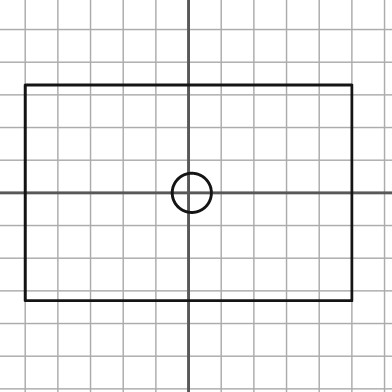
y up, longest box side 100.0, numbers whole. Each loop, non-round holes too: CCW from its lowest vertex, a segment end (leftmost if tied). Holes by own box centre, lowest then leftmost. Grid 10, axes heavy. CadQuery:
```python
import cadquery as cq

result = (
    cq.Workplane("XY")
    .moveTo(-50.0, -33.0)
    .lineTo(50.0, -33.0)
    .lineTo(50.0, 33.0)
    .lineTo(-50.0, 33.0)
    .close()
    .moveTo(1.0, 0.0)
    .circle(6.0)
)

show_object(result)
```